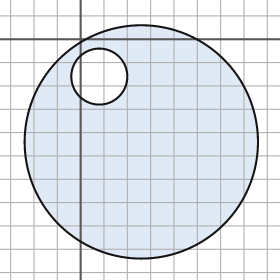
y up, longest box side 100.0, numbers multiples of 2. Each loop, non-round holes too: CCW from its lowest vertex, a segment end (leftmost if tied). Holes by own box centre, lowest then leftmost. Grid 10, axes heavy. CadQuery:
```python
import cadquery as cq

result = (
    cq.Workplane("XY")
    .moveTo(26.0, -44.0)
    .circle(50.0)
    .moveTo(8.0, -16.0)
    .circle(12.0)
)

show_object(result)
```